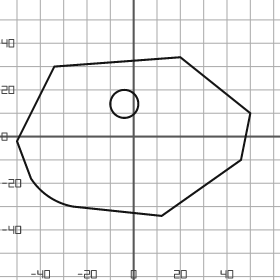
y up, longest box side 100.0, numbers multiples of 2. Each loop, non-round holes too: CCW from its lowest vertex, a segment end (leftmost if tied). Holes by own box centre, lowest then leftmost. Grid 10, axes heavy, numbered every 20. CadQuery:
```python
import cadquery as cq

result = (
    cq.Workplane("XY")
    .moveTo(12.0, -34.0)
    .lineTo(46.0, -10.0)
    .lineTo(50.0, 10.0)
    .lineTo(20.0, 34.0)
    .lineTo(-34.0, 30.0)
    .lineTo(-50.0, -2.0)
    .lineTo(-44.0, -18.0)
    .threePointArc((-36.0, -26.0), (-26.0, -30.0))
    .close()
    .moveTo(-4.0, 14.0)
    .circle(6.0)
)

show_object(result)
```